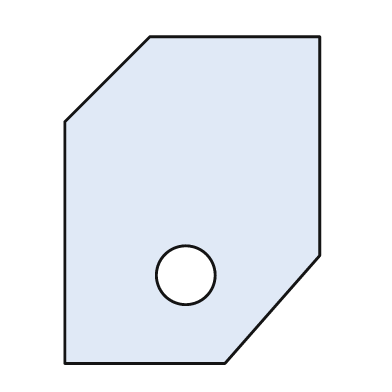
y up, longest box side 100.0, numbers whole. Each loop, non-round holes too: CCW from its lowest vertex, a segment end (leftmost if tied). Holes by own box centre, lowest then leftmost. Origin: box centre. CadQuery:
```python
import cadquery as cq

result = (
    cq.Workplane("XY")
    .moveTo(-39.0, -50.0)
    .lineTo(10.0, -50.0)
    .lineTo(39.0, -17.0)
    .lineTo(39.0, 50.0)
    .lineTo(-13.0, 50.0)
    .lineTo(-39.0, 24.0)
    .close()
    .moveTo(-2.0, -23.0)
    .circle(9.0)
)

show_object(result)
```